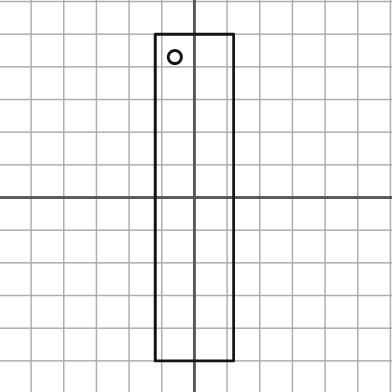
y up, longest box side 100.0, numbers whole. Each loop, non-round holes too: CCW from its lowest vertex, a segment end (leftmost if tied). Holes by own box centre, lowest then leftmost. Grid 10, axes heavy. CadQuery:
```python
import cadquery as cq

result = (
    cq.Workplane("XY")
    .moveTo(-12.0, -50.0)
    .lineTo(12.0, -50.0)
    .lineTo(12.0, 50.0)
    .lineTo(-12.0, 50.0)
    .close()
    .moveTo(-6.0, 43.0)
    .circle(2.0)
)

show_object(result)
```